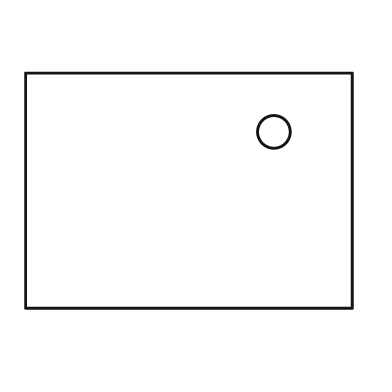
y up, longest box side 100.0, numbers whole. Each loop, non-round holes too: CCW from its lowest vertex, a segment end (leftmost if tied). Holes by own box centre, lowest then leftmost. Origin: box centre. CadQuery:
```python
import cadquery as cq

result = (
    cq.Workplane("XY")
    .moveTo(-50.0, -36.0)
    .lineTo(50.0, -36.0)
    .lineTo(50.0, 36.0)
    .lineTo(-50.0, 36.0)
    .close()
    .moveTo(26.0, 18.0)
    .circle(5.0)
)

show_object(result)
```